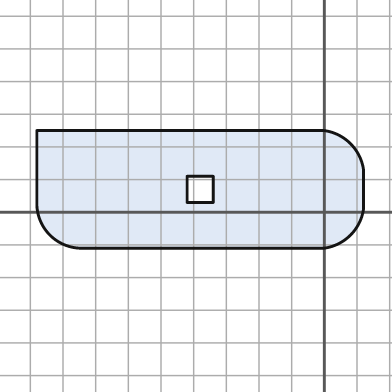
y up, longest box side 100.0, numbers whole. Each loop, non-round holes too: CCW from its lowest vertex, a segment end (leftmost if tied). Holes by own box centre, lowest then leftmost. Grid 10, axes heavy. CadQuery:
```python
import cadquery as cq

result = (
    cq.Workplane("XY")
    .moveTo(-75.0, -11.0)
    .lineTo(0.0, -11.0)
    .threePointArc((8.0, -7.0), (12.0, 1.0))
    .lineTo(12.0, 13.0)
    .threePointArc((8.0, 21.0), (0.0, 25.0))
    .lineTo(-88.0, 25.0)
    .lineTo(-88.0, 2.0)
    .threePointArc((-84.0, -7.0), (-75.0, -11.0))
    .close()
    .moveTo(-42.0, 3.0)
    .lineTo(-34.0, 3.0)
    .lineTo(-34.0, 11.0)
    .lineTo(-42.0, 11.0)
    .close()
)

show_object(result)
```